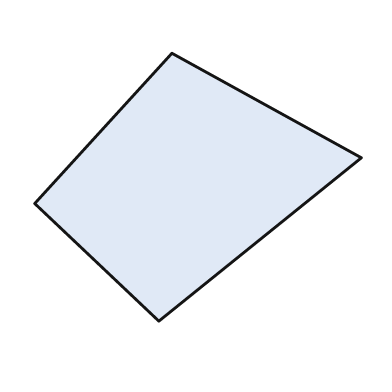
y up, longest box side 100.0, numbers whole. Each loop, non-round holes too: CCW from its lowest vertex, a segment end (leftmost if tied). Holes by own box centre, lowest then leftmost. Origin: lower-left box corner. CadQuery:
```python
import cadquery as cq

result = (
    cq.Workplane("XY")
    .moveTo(38.0, 0.0)
    .lineTo(100.0, 50.0)
    .lineTo(42.0, 82.0)
    .lineTo(0.0, 36.0)
    .close()
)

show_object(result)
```